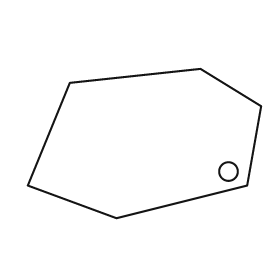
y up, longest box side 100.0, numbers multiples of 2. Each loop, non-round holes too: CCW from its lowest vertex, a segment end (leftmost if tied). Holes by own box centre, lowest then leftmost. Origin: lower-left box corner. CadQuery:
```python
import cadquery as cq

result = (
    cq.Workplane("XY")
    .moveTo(38.0, 0.0)
    .lineTo(94.0, 14.0)
    .lineTo(100.0, 48.0)
    .lineTo(74.0, 64.0)
    .lineTo(18.0, 58.0)
    .lineTo(0.0, 14.0)
    .close()
    .moveTo(86.0, 20.0)
    .circle(4.0)
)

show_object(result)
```